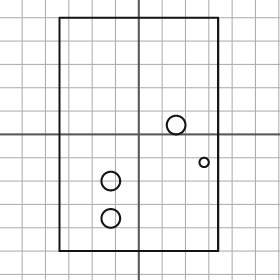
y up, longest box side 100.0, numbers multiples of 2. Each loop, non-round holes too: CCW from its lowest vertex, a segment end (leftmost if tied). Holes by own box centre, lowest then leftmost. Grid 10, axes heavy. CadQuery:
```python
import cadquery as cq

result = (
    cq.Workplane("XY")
    .moveTo(-34.0, -50.0)
    .lineTo(34.0, -50.0)
    .lineTo(34.0, 50.0)
    .lineTo(-34.0, 50.0)
    .close()
    .moveTo(-12.0, -36.0)
    .circle(4.0)
    .moveTo(-12.0, -20.0)
    .circle(4.0)
    .moveTo(28.0, -12.0)
    .circle(2.0)
    .moveTo(16.0, 4.0)
    .circle(4.0)
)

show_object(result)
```